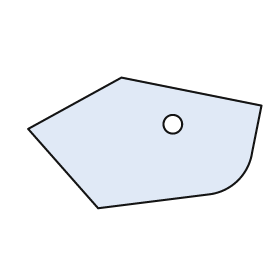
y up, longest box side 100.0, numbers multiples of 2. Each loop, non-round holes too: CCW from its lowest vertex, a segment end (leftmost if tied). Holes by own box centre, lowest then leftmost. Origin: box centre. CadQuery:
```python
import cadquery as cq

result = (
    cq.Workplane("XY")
    .moveTo(-20.0, -28.0)
    .lineTo(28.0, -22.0)
    .threePointArc((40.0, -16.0), (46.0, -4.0))
    .lineTo(50.0, 16.0)
    .lineTo(-10.0, 28.0)
    .lineTo(-50.0, 6.0)
    .close()
    .moveTo(12.0, 8.0)
    .circle(4.0)
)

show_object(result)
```